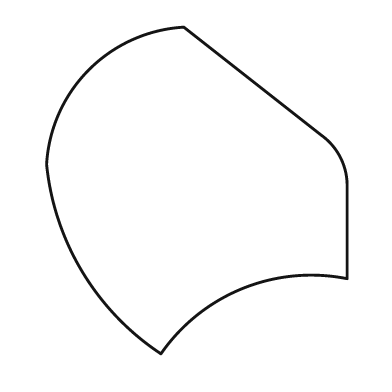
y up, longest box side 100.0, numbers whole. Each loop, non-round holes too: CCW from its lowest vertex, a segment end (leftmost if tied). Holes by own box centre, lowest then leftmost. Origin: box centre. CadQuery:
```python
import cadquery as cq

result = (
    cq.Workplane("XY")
    .moveTo(-11.0, -50.0)
    .threePointArc((14.0, -30.0), (46.0, -27.0))
    .lineTo(46.0, 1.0)
    .threePointArc((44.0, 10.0), (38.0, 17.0))
    .lineTo(-4.0, 50.0)
    .threePointArc((-33.0, 37.0), (-46.0, 8.0))
    .threePointArc((-35.0, -25.0), (-11.0, -50.0))
    .close()
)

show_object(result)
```